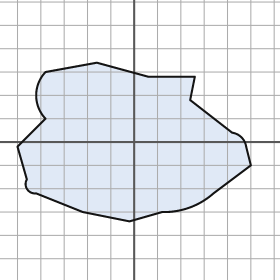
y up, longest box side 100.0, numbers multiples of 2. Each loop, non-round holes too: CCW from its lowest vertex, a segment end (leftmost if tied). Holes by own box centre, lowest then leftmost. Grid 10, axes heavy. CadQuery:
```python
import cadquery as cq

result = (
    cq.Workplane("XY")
    .moveTo(-2.0, -34.0)
    .lineTo(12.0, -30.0)
    .threePointArc((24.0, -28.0), (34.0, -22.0))
    .lineTo(50.0, -10.0)
    .lineTo(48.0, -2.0)
    .threePointArc((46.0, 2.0), (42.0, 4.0))
    .lineTo(24.0, 18.0)
    .lineTo(26.0, 28.0)
    .lineTo(6.0, 28.0)
    .lineTo(-16.0, 34.0)
    .lineTo(-38.0, 30.0)
    .threePointArc((-42.0, 20.0), (-38.0, 10.0))
    .lineTo(-50.0, -2.0)
    .lineTo(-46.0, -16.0)
    .threePointArc((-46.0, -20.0), (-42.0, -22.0))
    .lineTo(-22.0, -30.0)
    .close()
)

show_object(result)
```